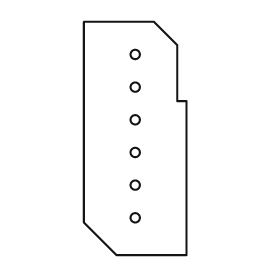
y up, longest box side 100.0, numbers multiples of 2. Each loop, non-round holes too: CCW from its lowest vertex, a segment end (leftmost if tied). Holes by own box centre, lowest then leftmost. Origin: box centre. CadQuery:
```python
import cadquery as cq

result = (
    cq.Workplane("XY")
    .moveTo(-8.0, -50.0)
    .lineTo(22.0, -50.0)
    .lineTo(22.0, 16.0)
    .lineTo(18.0, 16.0)
    .lineTo(18.0, 40.0)
    .lineTo(8.0, 50.0)
    .lineTo(-22.0, 50.0)
    .lineTo(-22.0, -36.0)
    .close()
    .moveTo(0.0, -34.0)
    .circle(2.0)
    .moveTo(0.0, -20.0)
    .circle(2.0)
    .moveTo(0.0, -6.0)
    .circle(2.0)
    .moveTo(0.0, 8.0)
    .circle(2.0)
    .moveTo(0.0, 22.0)
    .circle(2.0)
    .moveTo(0.0, 36.0)
    .circle(2.0)
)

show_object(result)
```